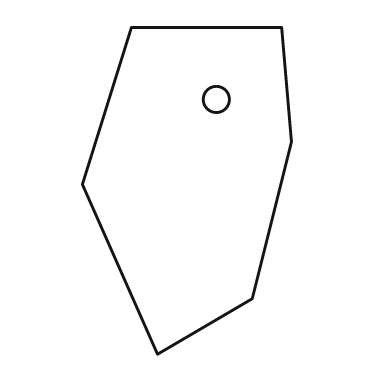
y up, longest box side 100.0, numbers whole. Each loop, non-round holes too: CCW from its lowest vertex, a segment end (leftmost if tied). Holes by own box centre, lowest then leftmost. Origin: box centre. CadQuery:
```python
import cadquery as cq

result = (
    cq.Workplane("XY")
    .moveTo(-9.0, -50.0)
    .lineTo(20.0, -33.0)
    .lineTo(32.0, 15.0)
    .lineTo(29.0, 50.0)
    .lineTo(-17.0, 50.0)
    .lineTo(-32.0, 2.0)
    .close()
    .moveTo(9.0, 28.0)
    .circle(4.0)
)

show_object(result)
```